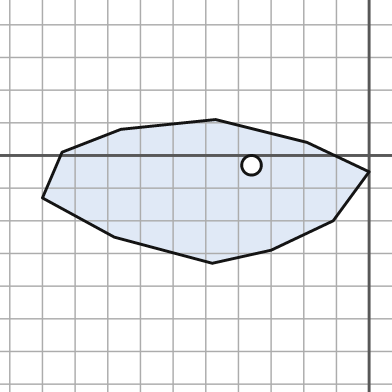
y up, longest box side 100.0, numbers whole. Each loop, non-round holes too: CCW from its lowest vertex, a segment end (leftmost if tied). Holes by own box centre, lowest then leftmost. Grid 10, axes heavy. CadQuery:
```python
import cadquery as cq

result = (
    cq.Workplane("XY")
    .moveTo(-48.0, -33.0)
    .lineTo(-30.0, -29.0)
    .lineTo(-11.0, -20.0)
    .lineTo(0.0, -5.0)
    .lineTo(-19.0, 4.0)
    .lineTo(-47.0, 11.0)
    .lineTo(-76.0, 8.0)
    .lineTo(-94.0, 1.0)
    .lineTo(-100.0, -13.0)
    .lineTo(-78.0, -25.0)
    .close()
    .moveTo(-36.0, -3.0)
    .circle(3.0)
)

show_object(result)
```